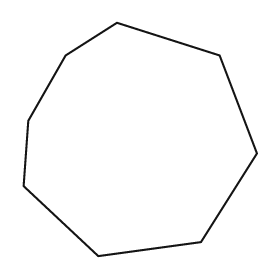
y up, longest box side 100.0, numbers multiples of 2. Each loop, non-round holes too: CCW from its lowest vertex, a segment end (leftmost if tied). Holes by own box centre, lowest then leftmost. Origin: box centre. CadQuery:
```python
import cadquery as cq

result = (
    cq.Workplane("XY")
    .moveTo(-18.0, -50.0)
    .lineTo(26.0, -44.0)
    .lineTo(50.0, -6.0)
    .lineTo(34.0, 36.0)
    .lineTo(-10.0, 50.0)
    .lineTo(-32.0, 36.0)
    .lineTo(-48.0, 8.0)
    .lineTo(-50.0, -20.0)
    .close()
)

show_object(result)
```